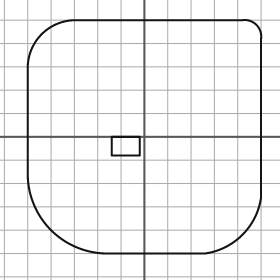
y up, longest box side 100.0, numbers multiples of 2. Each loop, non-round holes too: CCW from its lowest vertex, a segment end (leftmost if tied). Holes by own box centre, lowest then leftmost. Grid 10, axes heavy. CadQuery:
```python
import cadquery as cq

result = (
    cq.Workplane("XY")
    .moveTo(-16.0, -50.0)
    .lineTo(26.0, -50.0)
    .threePointArc((42.0, -42.0), (50.0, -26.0))
    .lineTo(50.0, 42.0)
    .threePointArc((48.0, 48.0), (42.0, 50.0))
    .lineTo(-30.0, 50.0)
    .threePointArc((-44.0, 44.0), (-50.0, 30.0))
    .lineTo(-50.0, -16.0)
    .threePointArc((-40.0, -40.0), (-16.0, -50.0))
    .close()
    .moveTo(-14.0, -8.0)
    .lineTo(-2.0, -8.0)
    .lineTo(-2.0, 0.0)
    .lineTo(-14.0, 0.0)
    .close()
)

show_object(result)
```